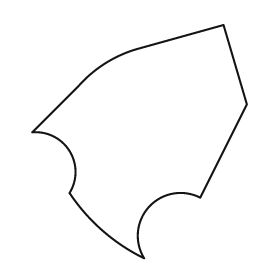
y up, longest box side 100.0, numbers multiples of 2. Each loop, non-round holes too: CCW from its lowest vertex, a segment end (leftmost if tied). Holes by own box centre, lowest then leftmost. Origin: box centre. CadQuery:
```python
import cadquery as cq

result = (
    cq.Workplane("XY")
    .moveTo(2.0, -50.0)
    .threePointArc((4.0, -28.0), (26.0, -24.0))
    .lineTo(46.0, 16.0)
    .lineTo(36.0, 50.0)
    .lineTo(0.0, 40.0)
    .threePointArc((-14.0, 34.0), (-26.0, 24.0))
    .lineTo(-46.0, 4.0)
    .threePointArc((-30.0, -4.0), (-30.0, -22.0))
    .threePointArc((-16.0, -38.0), (2.0, -50.0))
    .close()
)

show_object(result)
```